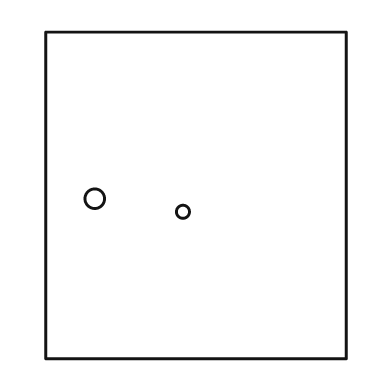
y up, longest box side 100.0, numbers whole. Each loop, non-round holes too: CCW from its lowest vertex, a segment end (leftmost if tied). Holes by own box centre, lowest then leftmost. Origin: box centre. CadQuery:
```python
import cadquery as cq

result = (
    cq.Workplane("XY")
    .moveTo(-46.0, -50.0)
    .lineTo(46.0, -50.0)
    .lineTo(46.0, 50.0)
    .lineTo(-46.0, 50.0)
    .close()
    .moveTo(-4.0, -5.0)
    .circle(2.0)
    .moveTo(-31.0, -1.0)
    .circle(3.0)
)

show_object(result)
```